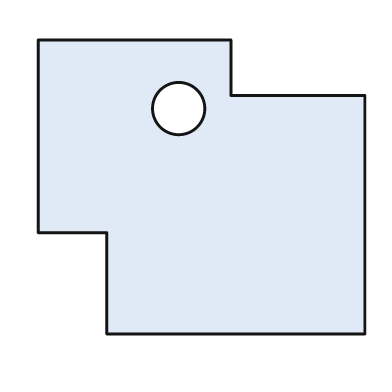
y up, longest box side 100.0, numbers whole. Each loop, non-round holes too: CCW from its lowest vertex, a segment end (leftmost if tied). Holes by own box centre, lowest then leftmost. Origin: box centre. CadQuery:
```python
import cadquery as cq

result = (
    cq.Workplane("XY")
    .moveTo(-29.0, -45.0)
    .lineTo(50.0, -45.0)
    .lineTo(50.0, 28.0)
    .lineTo(9.0, 28.0)
    .lineTo(9.0, 45.0)
    .lineTo(-50.0, 45.0)
    .lineTo(-50.0, -14.0)
    .lineTo(-29.0, -14.0)
    .close()
    .moveTo(-7.0, 24.0)
    .circle(8.0)
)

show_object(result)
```